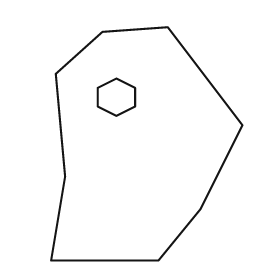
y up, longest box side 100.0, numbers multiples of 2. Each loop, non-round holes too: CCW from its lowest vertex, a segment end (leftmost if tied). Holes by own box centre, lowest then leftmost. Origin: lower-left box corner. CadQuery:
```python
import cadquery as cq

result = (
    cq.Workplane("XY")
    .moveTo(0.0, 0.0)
    .lineTo(46.0, 0.0)
    .lineTo(64.0, 22.0)
    .lineTo(82.0, 58.0)
    .lineTo(50.0, 100.0)
    .lineTo(22.0, 98.0)
    .lineTo(2.0, 80.0)
    .lineTo(6.0, 36.0)
    .close()
    .moveTo(28.0, 62.0)
    .lineTo(36.0, 66.0)
    .lineTo(36.0, 74.0)
    .lineTo(28.0, 78.0)
    .lineTo(20.0, 74.0)
    .lineTo(20.0, 66.0)
    .close()
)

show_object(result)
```